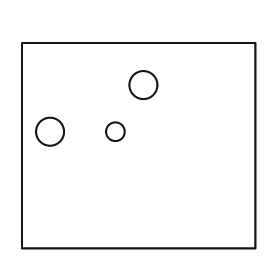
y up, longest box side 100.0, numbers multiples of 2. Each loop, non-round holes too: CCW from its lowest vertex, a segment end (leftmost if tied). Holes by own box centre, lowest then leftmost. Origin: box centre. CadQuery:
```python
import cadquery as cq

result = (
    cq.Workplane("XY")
    .moveTo(-50.0, -44.0)
    .lineTo(50.0, -44.0)
    .lineTo(50.0, 44.0)
    .lineTo(-50.0, 44.0)
    .close()
    .moveTo(-38.0, 6.0)
    .circle(6.0)
    .moveTo(-10.0, 6.0)
    .circle(4.0)
    .moveTo(2.0, 26.0)
    .circle(6.0)
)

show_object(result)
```